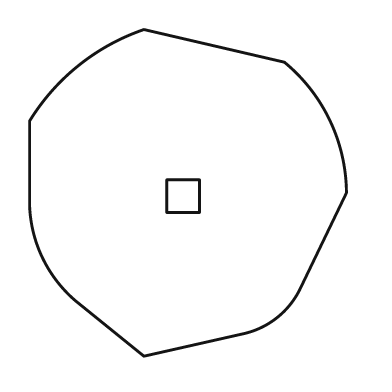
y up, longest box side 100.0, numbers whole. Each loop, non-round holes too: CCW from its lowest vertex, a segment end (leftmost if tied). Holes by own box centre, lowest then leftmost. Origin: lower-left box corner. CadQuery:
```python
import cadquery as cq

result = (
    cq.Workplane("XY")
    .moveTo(35.0, 0.0)
    .lineTo(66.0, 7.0)
    .threePointArc((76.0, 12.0), (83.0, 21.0))
    .lineTo(97.0, 50.0)
    .threePointArc((92.0, 72.0), (78.0, 90.0))
    .lineTo(35.0, 100.0)
    .threePointArc((15.0, 89.0), (0.0, 72.0))
    .lineTo(0.0, 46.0)
    .threePointArc((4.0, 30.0), (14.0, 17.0))
    .close()
    .moveTo(42.0, 44.0)
    .lineTo(52.0, 44.0)
    .lineTo(52.0, 54.0)
    .lineTo(42.0, 54.0)
    .close()
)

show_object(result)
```